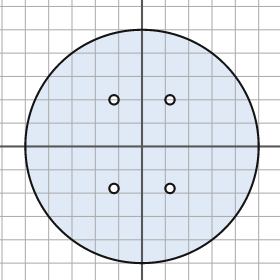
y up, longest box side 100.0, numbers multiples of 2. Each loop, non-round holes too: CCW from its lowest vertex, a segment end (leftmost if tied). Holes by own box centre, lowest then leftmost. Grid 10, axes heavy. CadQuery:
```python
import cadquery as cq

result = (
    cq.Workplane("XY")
    .moveTo(0.0, 0.0)
    .circle(50.0)
    .moveTo(-12.0, -18.0)
    .circle(2.0)
    .moveTo(12.0, -18.0)
    .circle(2.0)
    .moveTo(-12.0, 20.0)
    .circle(2.0)
    .moveTo(12.0, 20.0)
    .circle(2.0)
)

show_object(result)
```